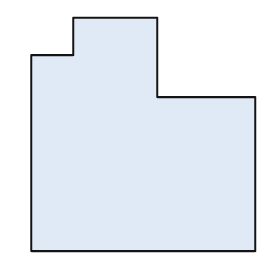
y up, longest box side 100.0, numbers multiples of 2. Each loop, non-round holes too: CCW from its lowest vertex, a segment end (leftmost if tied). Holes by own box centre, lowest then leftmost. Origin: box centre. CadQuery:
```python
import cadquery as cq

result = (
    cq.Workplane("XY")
    .moveTo(-48.0, -50.0)
    .lineTo(48.0, -50.0)
    .lineTo(48.0, 16.0)
    .lineTo(6.0, 16.0)
    .lineTo(6.0, 50.0)
    .lineTo(-30.0, 50.0)
    .lineTo(-30.0, 34.0)
    .lineTo(-48.0, 34.0)
    .close()
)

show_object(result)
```